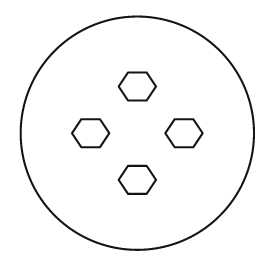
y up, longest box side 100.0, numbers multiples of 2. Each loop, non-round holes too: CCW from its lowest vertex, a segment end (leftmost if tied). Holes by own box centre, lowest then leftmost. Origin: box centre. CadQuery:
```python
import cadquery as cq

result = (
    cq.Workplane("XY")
    .moveTo(0.0, 0.0)
    .circle(50.0)
    .moveTo(-4.0, -26.0)
    .lineTo(4.0, -26.0)
    .lineTo(8.0, -20.0)
    .lineTo(4.0, -14.0)
    .lineTo(-4.0, -14.0)
    .lineTo(-8.0, -20.0)
    .close()
    .moveTo(-24.0, -6.0)
    .lineTo(-16.0, -6.0)
    .lineTo(-12.0, 0.0)
    .lineTo(-16.0, 6.0)
    .lineTo(-24.0, 6.0)
    .lineTo(-28.0, 0.0)
    .close()
    .moveTo(16.0, -6.0)
    .lineTo(24.0, -6.0)
    .lineTo(28.0, 0.0)
    .lineTo(24.0, 6.0)
    .lineTo(16.0, 6.0)
    .lineTo(12.0, 0.0)
    .close()
    .moveTo(-4.0, 14.0)
    .lineTo(4.0, 14.0)
    .lineTo(8.0, 20.0)
    .lineTo(4.0, 26.0)
    .lineTo(-4.0, 26.0)
    .lineTo(-8.0, 20.0)
    .close()
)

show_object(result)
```